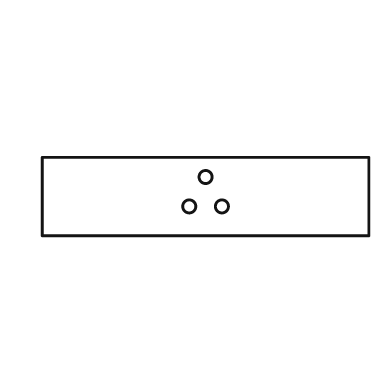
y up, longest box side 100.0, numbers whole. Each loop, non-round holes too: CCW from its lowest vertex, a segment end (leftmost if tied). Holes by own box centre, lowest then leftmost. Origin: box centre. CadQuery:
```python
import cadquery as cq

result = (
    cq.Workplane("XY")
    .moveTo(-50.0, -12.0)
    .lineTo(50.0, -12.0)
    .lineTo(50.0, 12.0)
    .lineTo(-50.0, 12.0)
    .close()
    .moveTo(-5.0, -3.0)
    .circle(2.0)
    .moveTo(5.0, -3.0)
    .circle(2.0)
    .moveTo(0.0, 6.0)
    .circle(2.0)
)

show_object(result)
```